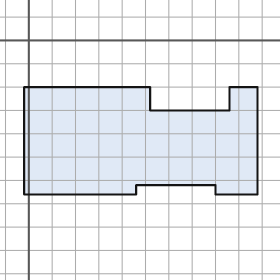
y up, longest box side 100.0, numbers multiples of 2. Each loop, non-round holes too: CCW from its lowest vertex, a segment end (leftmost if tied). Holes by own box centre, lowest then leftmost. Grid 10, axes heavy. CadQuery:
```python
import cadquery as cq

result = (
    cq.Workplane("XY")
    .moveTo(-2.0, -66.0)
    .lineTo(46.0, -66.0)
    .lineTo(46.0, -62.0)
    .lineTo(80.0, -62.0)
    .lineTo(80.0, -66.0)
    .lineTo(98.0, -66.0)
    .lineTo(98.0, -20.0)
    .lineTo(86.0, -20.0)
    .lineTo(86.0, -30.0)
    .lineTo(52.0, -30.0)
    .lineTo(52.0, -20.0)
    .lineTo(-2.0, -20.0)
    .close()
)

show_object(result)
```